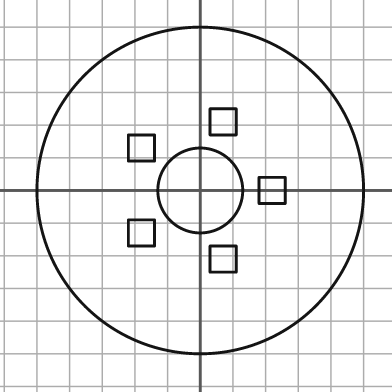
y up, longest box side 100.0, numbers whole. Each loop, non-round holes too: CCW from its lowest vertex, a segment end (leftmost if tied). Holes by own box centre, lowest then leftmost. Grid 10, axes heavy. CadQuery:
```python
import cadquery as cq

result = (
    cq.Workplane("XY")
    .moveTo(0.0, 0.0)
    .circle(50.0)
    .moveTo(3.0, -25.0)
    .lineTo(11.0, -25.0)
    .lineTo(11.0, -17.0)
    .lineTo(3.0, -17.0)
    .close()
    .moveTo(-22.0, -17.0)
    .lineTo(-14.0, -17.0)
    .lineTo(-14.0, -9.0)
    .lineTo(-22.0, -9.0)
    .close()
    .moveTo(0.0, 0.0)
    .circle(13.0)
    .moveTo(18.0, -4.0)
    .lineTo(26.0, -4.0)
    .lineTo(26.0, 4.0)
    .lineTo(18.0, 4.0)
    .close()
    .moveTo(-22.0, 9.0)
    .lineTo(-14.0, 9.0)
    .lineTo(-14.0, 17.0)
    .lineTo(-22.0, 17.0)
    .close()
    .moveTo(3.0, 17.0)
    .lineTo(11.0, 17.0)
    .lineTo(11.0, 25.0)
    .lineTo(3.0, 25.0)
    .close()
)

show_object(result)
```